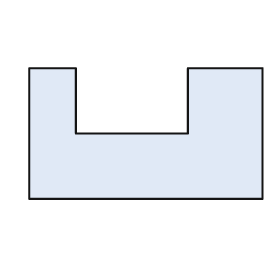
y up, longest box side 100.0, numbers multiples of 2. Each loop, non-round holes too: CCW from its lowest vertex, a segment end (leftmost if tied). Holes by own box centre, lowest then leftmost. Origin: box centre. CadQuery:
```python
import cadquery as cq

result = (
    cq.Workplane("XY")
    .moveTo(-50.0, -28.0)
    .lineTo(50.0, -28.0)
    .lineTo(50.0, 28.0)
    .lineTo(18.0, 28.0)
    .lineTo(18.0, 0.0)
    .lineTo(-30.0, 0.0)
    .lineTo(-30.0, 28.0)
    .lineTo(-50.0, 28.0)
    .close()
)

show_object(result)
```